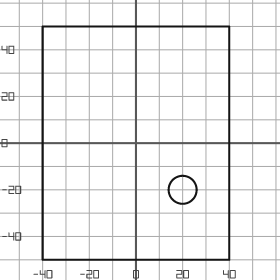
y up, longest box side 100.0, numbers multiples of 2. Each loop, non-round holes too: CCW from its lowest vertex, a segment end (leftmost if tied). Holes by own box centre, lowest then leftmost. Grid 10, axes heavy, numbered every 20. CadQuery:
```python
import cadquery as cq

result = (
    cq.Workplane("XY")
    .moveTo(-40.0, -50.0)
    .lineTo(40.0, -50.0)
    .lineTo(40.0, 50.0)
    .lineTo(-40.0, 50.0)
    .close()
    .moveTo(20.0, -20.0)
    .circle(6.0)
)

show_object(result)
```